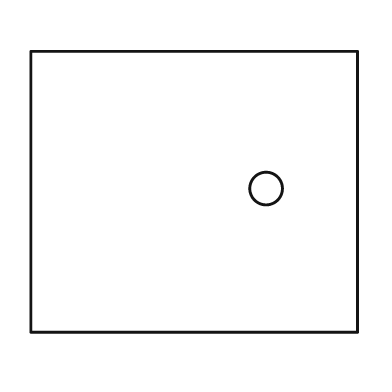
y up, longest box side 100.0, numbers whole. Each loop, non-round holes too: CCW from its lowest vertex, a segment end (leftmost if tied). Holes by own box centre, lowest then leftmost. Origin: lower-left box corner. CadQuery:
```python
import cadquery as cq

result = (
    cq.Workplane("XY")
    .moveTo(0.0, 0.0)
    .lineTo(100.0, 0.0)
    .lineTo(100.0, 86.0)
    .lineTo(0.0, 86.0)
    .close()
    .moveTo(72.0, 44.0)
    .circle(5.0)
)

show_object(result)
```